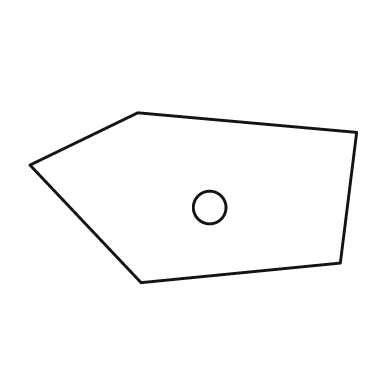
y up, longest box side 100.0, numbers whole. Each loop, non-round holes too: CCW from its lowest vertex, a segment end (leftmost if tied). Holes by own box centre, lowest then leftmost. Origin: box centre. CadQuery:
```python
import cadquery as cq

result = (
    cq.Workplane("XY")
    .moveTo(-16.0, -26.0)
    .lineTo(45.0, -20.0)
    .lineTo(50.0, 20.0)
    .lineTo(-17.0, 26.0)
    .lineTo(-50.0, 10.0)
    .close()
    .moveTo(5.0, -3.0)
    .circle(5.0)
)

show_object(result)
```